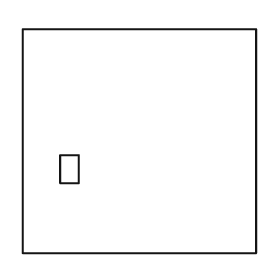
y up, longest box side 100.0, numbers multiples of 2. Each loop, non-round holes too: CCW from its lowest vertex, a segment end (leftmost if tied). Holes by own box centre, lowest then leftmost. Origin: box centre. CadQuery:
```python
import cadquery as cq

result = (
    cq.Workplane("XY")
    .moveTo(-50.0, -48.0)
    .lineTo(50.0, -48.0)
    .lineTo(50.0, 48.0)
    .lineTo(-50.0, 48.0)
    .close()
    .moveTo(-34.0, -18.0)
    .lineTo(-26.0, -18.0)
    .lineTo(-26.0, -6.0)
    .lineTo(-34.0, -6.0)
    .close()
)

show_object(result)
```